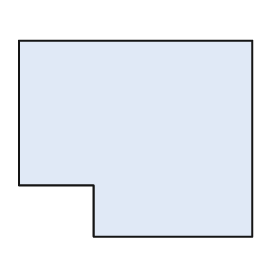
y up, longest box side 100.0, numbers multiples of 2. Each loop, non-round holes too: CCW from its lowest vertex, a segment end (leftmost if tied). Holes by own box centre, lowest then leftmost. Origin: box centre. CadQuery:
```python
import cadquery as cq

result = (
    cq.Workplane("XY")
    .moveTo(-18.0, -42.0)
    .lineTo(50.0, -42.0)
    .lineTo(50.0, 42.0)
    .lineTo(-50.0, 42.0)
    .lineTo(-50.0, -20.0)
    .lineTo(-18.0, -20.0)
    .close()
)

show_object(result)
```